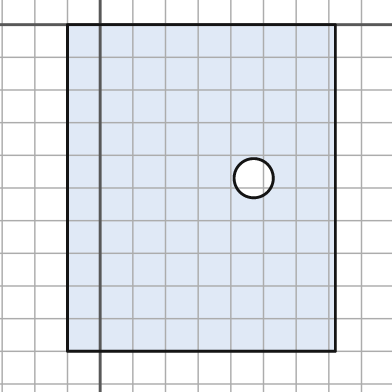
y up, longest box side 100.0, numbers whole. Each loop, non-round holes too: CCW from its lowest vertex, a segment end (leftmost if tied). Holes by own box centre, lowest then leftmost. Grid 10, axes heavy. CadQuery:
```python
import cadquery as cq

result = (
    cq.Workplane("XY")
    .moveTo(-10.0, -100.0)
    .lineTo(72.0, -100.0)
    .lineTo(72.0, 0.0)
    .lineTo(-10.0, 0.0)
    .close()
    .moveTo(47.0, -47.0)
    .circle(6.0)
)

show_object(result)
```